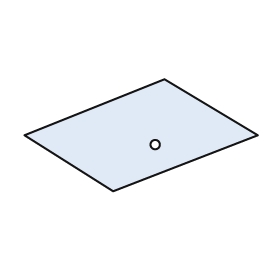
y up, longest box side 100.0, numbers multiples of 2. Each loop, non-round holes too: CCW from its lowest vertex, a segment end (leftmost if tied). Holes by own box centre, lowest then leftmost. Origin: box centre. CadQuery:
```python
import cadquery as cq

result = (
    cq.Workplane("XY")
    .moveTo(-12.0, -24.0)
    .lineTo(50.0, 0.0)
    .lineTo(10.0, 24.0)
    .lineTo(-50.0, 0.0)
    .close()
    .moveTo(6.0, -4.0)
    .circle(2.0)
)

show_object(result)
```